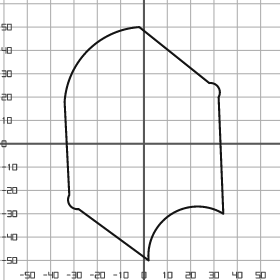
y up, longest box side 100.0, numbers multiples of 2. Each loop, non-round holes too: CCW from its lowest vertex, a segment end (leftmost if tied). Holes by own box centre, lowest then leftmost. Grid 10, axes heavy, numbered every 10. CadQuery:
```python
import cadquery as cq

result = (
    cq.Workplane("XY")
    .moveTo(2.0, -50.0)
    .threePointArc((12.0, -30.0), (34.0, -30.0))
    .lineTo(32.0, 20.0)
    .threePointArc((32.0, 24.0), (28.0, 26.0))
    .lineTo(-2.0, 50.0)
    .threePointArc((-24.0, 40.0), (-34.0, 18.0))
    .lineTo(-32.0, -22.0)
    .threePointArc((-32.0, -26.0), (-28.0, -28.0))
    .close()
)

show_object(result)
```